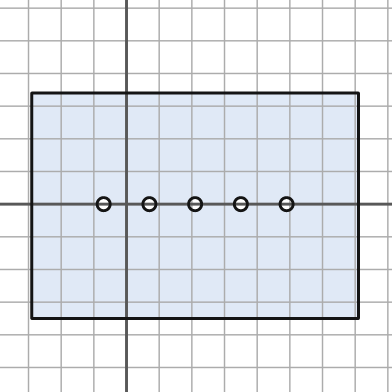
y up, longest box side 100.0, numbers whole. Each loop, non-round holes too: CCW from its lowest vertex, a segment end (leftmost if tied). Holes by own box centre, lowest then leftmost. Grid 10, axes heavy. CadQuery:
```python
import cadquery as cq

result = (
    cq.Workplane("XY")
    .moveTo(-29.0, -35.0)
    .lineTo(71.0, -35.0)
    .lineTo(71.0, 34.0)
    .lineTo(-29.0, 34.0)
    .close()
    .moveTo(-7.0, 0.0)
    .circle(2.0)
    .moveTo(7.0, 0.0)
    .circle(2.0)
    .moveTo(21.0, 0.0)
    .circle(2.0)
    .moveTo(35.0, 0.0)
    .circle(2.0)
    .moveTo(49.0, 0.0)
    .circle(2.0)
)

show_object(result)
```